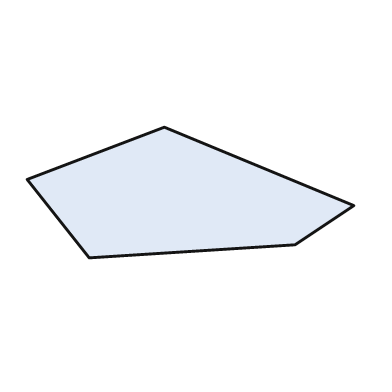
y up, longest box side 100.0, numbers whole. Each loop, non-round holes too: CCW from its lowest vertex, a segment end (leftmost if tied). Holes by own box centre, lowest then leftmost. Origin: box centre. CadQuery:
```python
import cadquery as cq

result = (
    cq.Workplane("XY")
    .moveTo(-31.0, -20.0)
    .lineTo(32.0, -16.0)
    .lineTo(50.0, -4.0)
    .lineTo(-8.0, 20.0)
    .lineTo(-50.0, 4.0)
    .close()
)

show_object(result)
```